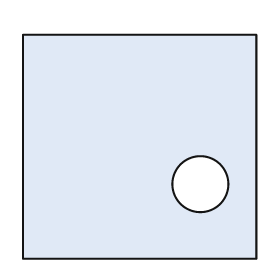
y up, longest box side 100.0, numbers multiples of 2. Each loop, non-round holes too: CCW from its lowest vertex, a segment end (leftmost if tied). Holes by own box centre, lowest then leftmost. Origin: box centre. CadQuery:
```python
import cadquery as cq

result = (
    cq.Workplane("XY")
    .moveTo(-50.0, -48.0)
    .lineTo(50.0, -48.0)
    .lineTo(50.0, 48.0)
    .lineTo(-50.0, 48.0)
    .close()
    .moveTo(26.0, -16.0)
    .circle(12.0)
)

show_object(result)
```